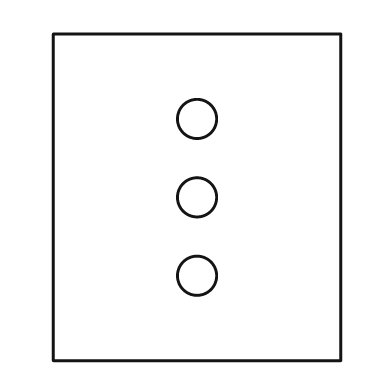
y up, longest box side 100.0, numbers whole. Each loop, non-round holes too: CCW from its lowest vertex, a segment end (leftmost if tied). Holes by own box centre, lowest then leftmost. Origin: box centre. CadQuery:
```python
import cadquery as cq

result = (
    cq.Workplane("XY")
    .moveTo(-44.0, -50.0)
    .lineTo(44.0, -50.0)
    .lineTo(44.0, 50.0)
    .lineTo(-44.0, 50.0)
    .close()
    .moveTo(0.0, -24.0)
    .circle(6.0)
    .moveTo(0.0, 0.0)
    .circle(6.0)
    .moveTo(0.0, 24.0)
    .circle(6.0)
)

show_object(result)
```